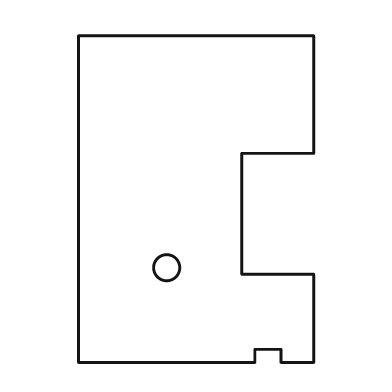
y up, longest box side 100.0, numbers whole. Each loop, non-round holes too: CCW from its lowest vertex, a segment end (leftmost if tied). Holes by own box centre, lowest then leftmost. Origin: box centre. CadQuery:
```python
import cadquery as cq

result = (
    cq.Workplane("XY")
    .moveTo(-36.0, -50.0)
    .lineTo(18.0, -50.0)
    .lineTo(18.0, -46.0)
    .lineTo(26.0, -46.0)
    .lineTo(26.0, -50.0)
    .lineTo(36.0, -50.0)
    .lineTo(36.0, -23.0)
    .lineTo(14.0, -23.0)
    .lineTo(14.0, 14.0)
    .lineTo(36.0, 14.0)
    .lineTo(36.0, 50.0)
    .lineTo(-36.0, 50.0)
    .close()
    .moveTo(-9.0, -21.0)
    .circle(4.0)
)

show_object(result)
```